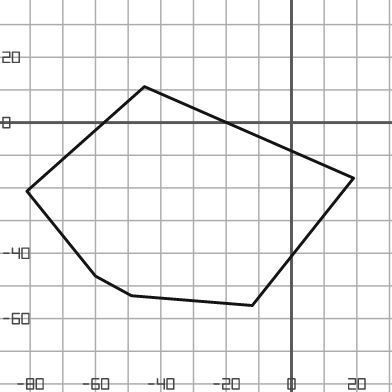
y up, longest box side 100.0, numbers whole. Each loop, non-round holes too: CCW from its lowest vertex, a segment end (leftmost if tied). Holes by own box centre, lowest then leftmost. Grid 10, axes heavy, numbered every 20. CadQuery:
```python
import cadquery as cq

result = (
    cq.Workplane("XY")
    .moveTo(-12.0, -56.0)
    .lineTo(19.0, -17.0)
    .lineTo(-45.0, 11.0)
    .lineTo(-81.0, -21.0)
    .lineTo(-60.0, -47.0)
    .lineTo(-49.0, -53.0)
    .close()
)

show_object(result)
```